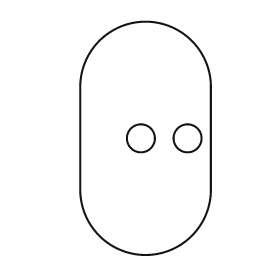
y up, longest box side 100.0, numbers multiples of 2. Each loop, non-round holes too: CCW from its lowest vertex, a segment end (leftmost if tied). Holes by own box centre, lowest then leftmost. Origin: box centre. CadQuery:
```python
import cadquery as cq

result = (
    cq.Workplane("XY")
    .moveTo(-28.0, -22.0)
    .threePointArc((0.0, -50.0), (28.0, -22.0))
    .lineTo(28.0, 22.0)
    .threePointArc((0.0, 50.0), (-28.0, 22.0))
    .close()
    .moveTo(-2.0, 0.0)
    .circle(6.0)
    .moveTo(18.0, 0.0)
    .circle(6.0)
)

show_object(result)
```